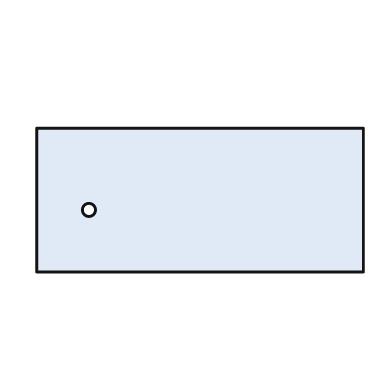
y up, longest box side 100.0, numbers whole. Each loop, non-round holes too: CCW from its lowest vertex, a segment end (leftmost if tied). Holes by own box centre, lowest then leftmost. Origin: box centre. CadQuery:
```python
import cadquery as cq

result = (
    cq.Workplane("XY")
    .moveTo(-50.0, -22.0)
    .lineTo(50.0, -22.0)
    .lineTo(50.0, 22.0)
    .lineTo(-50.0, 22.0)
    .close()
    .moveTo(-34.0, -3.0)
    .circle(2.0)
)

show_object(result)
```